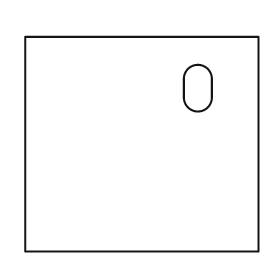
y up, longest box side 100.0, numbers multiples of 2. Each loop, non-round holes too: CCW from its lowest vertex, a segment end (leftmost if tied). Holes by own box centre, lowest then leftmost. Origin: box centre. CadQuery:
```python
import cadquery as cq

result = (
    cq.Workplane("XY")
    .moveTo(-50.0, -46.0)
    .lineTo(50.0, -46.0)
    .lineTo(50.0, 46.0)
    .lineTo(-50.0, 46.0)
    .close()
    .moveTo(18.0, 20.0)
    .threePointArc((24.0, 14.0), (30.0, 20.0))
    .lineTo(30.0, 28.0)
    .threePointArc((24.0, 34.0), (18.0, 28.0))
    .close()
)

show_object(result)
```